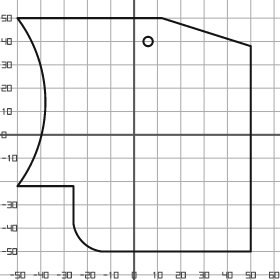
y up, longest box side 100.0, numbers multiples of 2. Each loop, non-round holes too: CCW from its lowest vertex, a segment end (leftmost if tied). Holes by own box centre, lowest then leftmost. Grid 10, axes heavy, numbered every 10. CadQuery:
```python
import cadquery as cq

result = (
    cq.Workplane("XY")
    .moveTo(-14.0, -50.0)
    .lineTo(50.0, -50.0)
    .lineTo(50.0, 38.0)
    .lineTo(12.0, 50.0)
    .lineTo(-50.0, 50.0)
    .threePointArc((-38.0, 14.0), (-50.0, -22.0))
    .lineTo(-26.0, -22.0)
    .lineTo(-26.0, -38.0)
    .threePointArc((-22.0, -46.0), (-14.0, -50.0))
    .close()
    .moveTo(6.0, 40.0)
    .circle(2.0)
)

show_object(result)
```